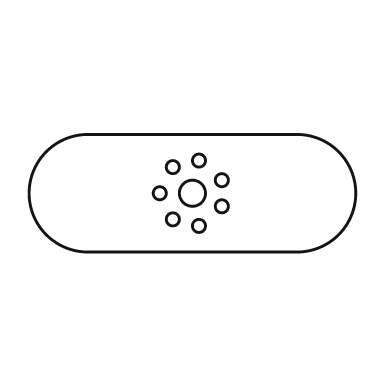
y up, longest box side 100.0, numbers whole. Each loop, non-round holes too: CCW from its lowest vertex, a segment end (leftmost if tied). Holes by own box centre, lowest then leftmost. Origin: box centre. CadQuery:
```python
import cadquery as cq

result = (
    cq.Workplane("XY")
    .moveTo(-32.0, -18.0)
    .lineTo(32.0, -18.0)
    .threePointArc((50.0, 0.0), (32.0, 18.0))
    .lineTo(-32.0, 18.0)
    .threePointArc((-50.0, 0.0), (-32.0, -18.0))
    .close()
    .moveTo(2.0, -10.0)
    .circle(2.0)
    .moveTo(-6.0, -8.0)
    .circle(2.0)
    .moveTo(9.0, -4.0)
    .circle(2.0)
    .moveTo(-10.0, 0.0)
    .circle(2.0)
    .moveTo(0.0, 0.0)
    .circle(4.0)
    .moveTo(9.0, 4.0)
    .circle(2.0)
    .moveTo(-6.0, 8.0)
    .circle(2.0)
    .moveTo(2.0, 10.0)
    .circle(2.0)
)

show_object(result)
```